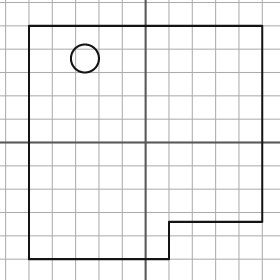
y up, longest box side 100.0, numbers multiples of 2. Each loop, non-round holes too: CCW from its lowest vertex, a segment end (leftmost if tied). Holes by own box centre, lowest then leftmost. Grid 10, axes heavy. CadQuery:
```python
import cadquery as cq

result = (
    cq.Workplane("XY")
    .moveTo(-50.0, -50.0)
    .lineTo(10.0, -50.0)
    .lineTo(10.0, -34.0)
    .lineTo(50.0, -34.0)
    .lineTo(50.0, 50.0)
    .lineTo(-50.0, 50.0)
    .close()
    .moveTo(-26.0, 36.0)
    .circle(6.0)
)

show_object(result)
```